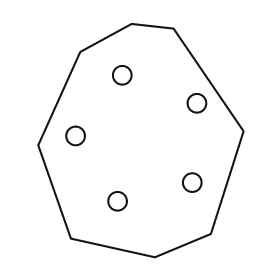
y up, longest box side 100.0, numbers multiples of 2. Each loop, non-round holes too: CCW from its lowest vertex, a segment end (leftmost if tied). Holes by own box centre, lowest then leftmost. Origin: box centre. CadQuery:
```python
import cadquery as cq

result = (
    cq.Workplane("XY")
    .moveTo(6.0, -50.0)
    .lineTo(30.0, -40.0)
    .lineTo(44.0, 4.0)
    .lineTo(14.0, 48.0)
    .lineTo(-4.0, 50.0)
    .lineTo(-26.0, 38.0)
    .lineTo(-44.0, -2.0)
    .lineTo(-30.0, -42.0)
    .close()
    .moveTo(-10.0, -26.0)
    .circle(4.0)
    .moveTo(22.0, -18.0)
    .circle(4.0)
    .moveTo(-28.0, 2.0)
    .circle(4.0)
    .moveTo(24.0, 16.0)
    .circle(4.0)
    .moveTo(-8.0, 28.0)
    .circle(4.0)
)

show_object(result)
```